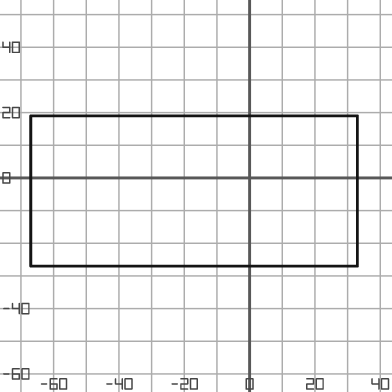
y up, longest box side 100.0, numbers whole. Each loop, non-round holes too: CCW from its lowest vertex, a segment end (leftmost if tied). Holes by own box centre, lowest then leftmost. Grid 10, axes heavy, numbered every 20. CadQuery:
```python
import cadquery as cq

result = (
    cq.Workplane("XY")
    .moveTo(-67.0, -27.0)
    .lineTo(33.0, -27.0)
    .lineTo(33.0, 19.0)
    .lineTo(-67.0, 19.0)
    .close()
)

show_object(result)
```